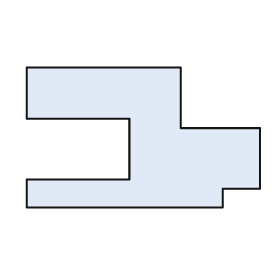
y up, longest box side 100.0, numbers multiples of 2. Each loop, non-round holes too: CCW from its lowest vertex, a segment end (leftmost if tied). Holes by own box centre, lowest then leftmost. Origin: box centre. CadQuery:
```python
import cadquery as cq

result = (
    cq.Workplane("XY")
    .moveTo(-50.0, -30.0)
    .lineTo(34.0, -30.0)
    .lineTo(34.0, -22.0)
    .lineTo(50.0, -22.0)
    .lineTo(50.0, 4.0)
    .lineTo(16.0, 4.0)
    .lineTo(16.0, 30.0)
    .lineTo(-50.0, 30.0)
    .lineTo(-50.0, 8.0)
    .lineTo(-6.0, 8.0)
    .lineTo(-6.0, -18.0)
    .lineTo(-50.0, -18.0)
    .close()
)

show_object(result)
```